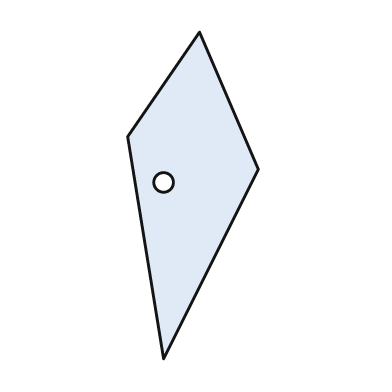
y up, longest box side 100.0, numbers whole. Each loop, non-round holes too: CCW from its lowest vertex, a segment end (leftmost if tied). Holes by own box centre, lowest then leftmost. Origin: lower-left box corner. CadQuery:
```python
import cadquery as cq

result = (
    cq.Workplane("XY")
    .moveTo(11.0, 0.0)
    .lineTo(40.0, 58.0)
    .lineTo(22.0, 100.0)
    .lineTo(0.0, 68.0)
    .close()
    .moveTo(11.0, 54.0)
    .circle(3.0)
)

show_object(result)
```